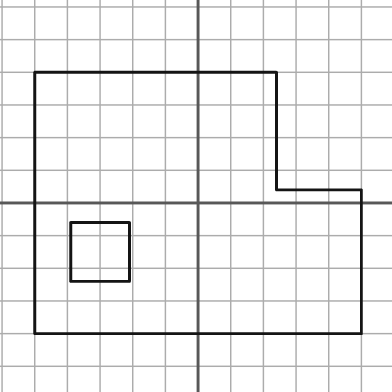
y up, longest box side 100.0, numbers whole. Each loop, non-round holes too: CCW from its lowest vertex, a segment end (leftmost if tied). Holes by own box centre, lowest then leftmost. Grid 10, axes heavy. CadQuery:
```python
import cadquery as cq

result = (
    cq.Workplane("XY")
    .moveTo(-50.0, -40.0)
    .lineTo(50.0, -40.0)
    .lineTo(50.0, 4.0)
    .lineTo(24.0, 4.0)
    .lineTo(24.0, 40.0)
    .lineTo(-50.0, 40.0)
    .close()
    .moveTo(-39.0, -24.0)
    .lineTo(-21.0, -24.0)
    .lineTo(-21.0, -6.0)
    .lineTo(-39.0, -6.0)
    .close()
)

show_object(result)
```